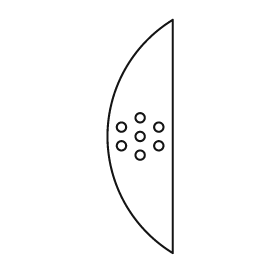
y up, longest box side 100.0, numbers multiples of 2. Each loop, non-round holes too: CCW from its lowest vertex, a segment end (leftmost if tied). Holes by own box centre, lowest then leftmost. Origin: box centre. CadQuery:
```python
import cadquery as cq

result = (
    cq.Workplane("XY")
    .moveTo(14.0, -50.0)
    .lineTo(14.0, 50.0)
    .threePointArc((-14.0, 0.0), (14.0, -50.0))
    .close()
    .moveTo(0.0, -8.0)
    .circle(2.0)
    .moveTo(-8.0, -4.0)
    .circle(2.0)
    .moveTo(8.0, -4.0)
    .circle(2.0)
    .moveTo(0.0, 0.0)
    .circle(2.0)
    .moveTo(-8.0, 4.0)
    .circle(2.0)
    .moveTo(8.0, 4.0)
    .circle(2.0)
    .moveTo(0.0, 8.0)
    .circle(2.0)
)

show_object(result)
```